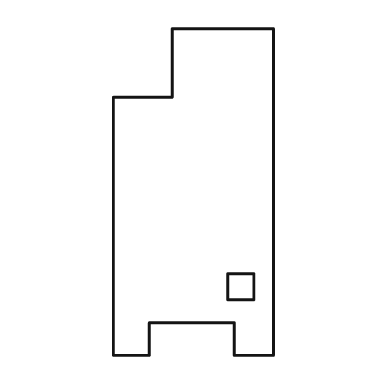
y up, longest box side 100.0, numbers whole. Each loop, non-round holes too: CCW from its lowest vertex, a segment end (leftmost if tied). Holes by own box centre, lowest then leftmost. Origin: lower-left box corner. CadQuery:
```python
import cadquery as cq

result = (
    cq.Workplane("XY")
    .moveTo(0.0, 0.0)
    .lineTo(11.0, 0.0)
    .lineTo(11.0, 10.0)
    .lineTo(37.0, 10.0)
    .lineTo(37.0, 0.0)
    .lineTo(49.0, 0.0)
    .lineTo(49.0, 100.0)
    .lineTo(18.0, 100.0)
    .lineTo(18.0, 79.0)
    .lineTo(0.0, 79.0)
    .close()
    .moveTo(35.0, 17.0)
    .lineTo(43.0, 17.0)
    .lineTo(43.0, 25.0)
    .lineTo(35.0, 25.0)
    .close()
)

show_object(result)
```